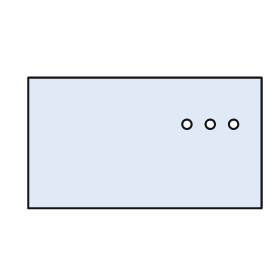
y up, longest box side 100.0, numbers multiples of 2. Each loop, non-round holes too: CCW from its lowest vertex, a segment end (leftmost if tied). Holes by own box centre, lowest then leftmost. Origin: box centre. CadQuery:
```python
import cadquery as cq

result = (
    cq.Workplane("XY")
    .moveTo(-50.0, -28.0)
    .lineTo(50.0, -28.0)
    .lineTo(50.0, 28.0)
    .lineTo(-50.0, 28.0)
    .close()
    .moveTo(18.0, 8.0)
    .circle(2.0)
    .moveTo(28.0, 8.0)
    .circle(2.0)
    .moveTo(38.0, 8.0)
    .circle(2.0)
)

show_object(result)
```